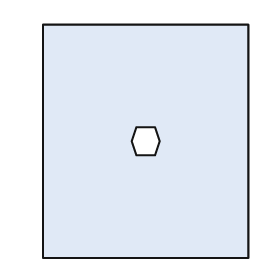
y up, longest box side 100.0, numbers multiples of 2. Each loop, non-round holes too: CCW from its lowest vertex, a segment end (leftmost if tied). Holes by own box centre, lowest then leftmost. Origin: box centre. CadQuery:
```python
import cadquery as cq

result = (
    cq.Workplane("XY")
    .moveTo(-44.0, -50.0)
    .lineTo(44.0, -50.0)
    .lineTo(44.0, 50.0)
    .lineTo(-44.0, 50.0)
    .close()
    .moveTo(-4.0, -6.0)
    .lineTo(4.0, -6.0)
    .lineTo(6.0, 0.0)
    .lineTo(4.0, 6.0)
    .lineTo(-4.0, 6.0)
    .lineTo(-6.0, 0.0)
    .close()
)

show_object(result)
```